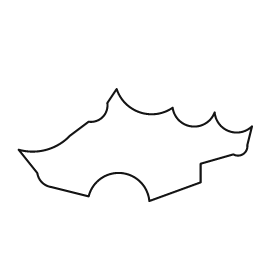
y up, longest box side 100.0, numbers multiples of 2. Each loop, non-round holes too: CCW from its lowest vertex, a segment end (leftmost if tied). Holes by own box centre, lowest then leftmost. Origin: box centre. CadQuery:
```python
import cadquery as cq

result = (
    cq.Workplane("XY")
    .moveTo(6.0, -24.0)
    .lineTo(28.0, -16.0)
    .lineTo(28.0, -8.0)
    .lineTo(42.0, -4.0)
    .threePointArc((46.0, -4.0), (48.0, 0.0))
    .lineTo(50.0, 8.0)
    .threePointArc((40.0, 6.0), (34.0, 14.0))
    .threePointArc((24.0, 8.0), (16.0, 16.0))
    .threePointArc((2.0, 14.0), (-8.0, 24.0))
    .lineTo(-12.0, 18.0)
    .threePointArc((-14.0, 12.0), (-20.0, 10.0))
    .lineTo(-28.0, 4.0)
    .threePointArc((-38.0, -2.0), (-50.0, -2.0))
    .lineTo(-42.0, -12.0)
    .threePointArc((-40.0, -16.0), (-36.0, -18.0))
    .lineTo(-20.0, -22.0)
    .threePointArc((-6.0, -12.0), (6.0, -24.0))
    .close()
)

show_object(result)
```